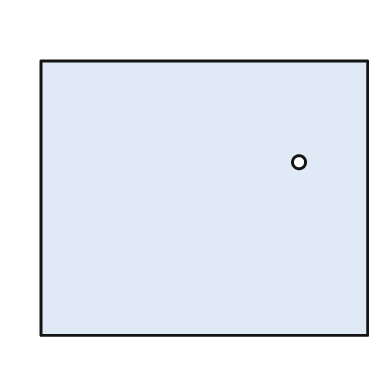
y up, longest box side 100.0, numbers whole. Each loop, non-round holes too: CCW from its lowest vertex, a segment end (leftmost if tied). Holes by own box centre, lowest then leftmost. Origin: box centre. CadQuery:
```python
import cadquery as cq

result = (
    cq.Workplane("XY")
    .moveTo(-50.0, -42.0)
    .lineTo(50.0, -42.0)
    .lineTo(50.0, 42.0)
    .lineTo(-50.0, 42.0)
    .close()
    .moveTo(29.0, 11.0)
    .circle(2.0)
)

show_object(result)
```